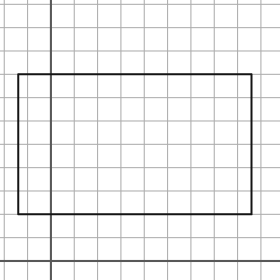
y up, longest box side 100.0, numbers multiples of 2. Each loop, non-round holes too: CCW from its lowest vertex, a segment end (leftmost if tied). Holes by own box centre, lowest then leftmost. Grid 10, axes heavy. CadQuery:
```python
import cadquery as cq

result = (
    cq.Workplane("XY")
    .moveTo(-14.0, 20.0)
    .lineTo(86.0, 20.0)
    .lineTo(86.0, 80.0)
    .lineTo(-14.0, 80.0)
    .close()
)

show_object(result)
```